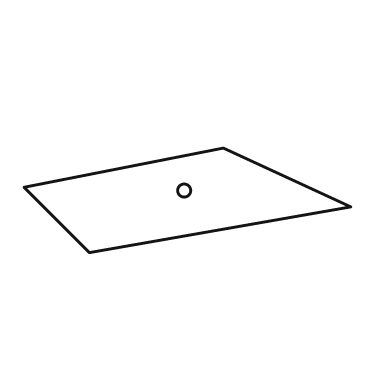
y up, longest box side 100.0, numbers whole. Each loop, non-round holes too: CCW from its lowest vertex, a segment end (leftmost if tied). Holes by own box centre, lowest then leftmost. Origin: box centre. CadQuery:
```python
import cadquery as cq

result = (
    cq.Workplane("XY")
    .moveTo(-30.0, -16.0)
    .lineTo(50.0, -2.0)
    .lineTo(11.0, 16.0)
    .lineTo(-50.0, 4.0)
    .close()
    .moveTo(-1.0, 3.0)
    .circle(2.0)
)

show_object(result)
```